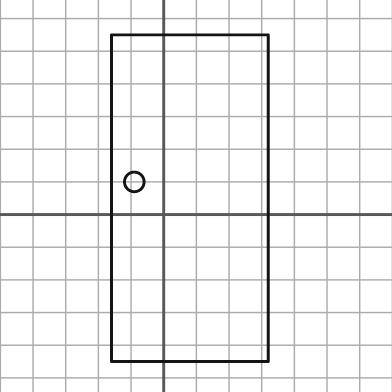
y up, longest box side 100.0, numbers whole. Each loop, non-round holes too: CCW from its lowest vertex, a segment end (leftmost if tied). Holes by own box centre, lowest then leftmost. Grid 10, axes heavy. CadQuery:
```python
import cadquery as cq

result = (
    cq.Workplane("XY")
    .moveTo(-16.0, -45.0)
    .lineTo(32.0, -45.0)
    .lineTo(32.0, 55.0)
    .lineTo(-16.0, 55.0)
    .close()
    .moveTo(-9.0, 10.0)
    .circle(3.0)
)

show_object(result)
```